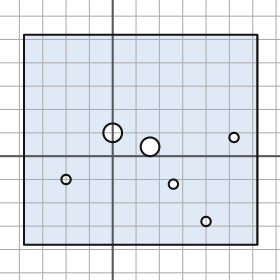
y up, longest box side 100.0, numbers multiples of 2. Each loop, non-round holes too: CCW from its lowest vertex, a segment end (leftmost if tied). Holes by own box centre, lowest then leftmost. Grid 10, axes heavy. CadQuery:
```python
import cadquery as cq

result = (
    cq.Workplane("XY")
    .moveTo(-38.0, -38.0)
    .lineTo(62.0, -38.0)
    .lineTo(62.0, 52.0)
    .lineTo(-38.0, 52.0)
    .close()
    .moveTo(40.0, -28.0)
    .circle(2.0)
    .moveTo(26.0, -12.0)
    .circle(2.0)
    .moveTo(-20.0, -10.0)
    .circle(2.0)
    .moveTo(16.0, 4.0)
    .circle(4.0)
    .moveTo(52.0, 8.0)
    .circle(2.0)
    .moveTo(0.0, 10.0)
    .circle(4.0)
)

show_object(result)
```